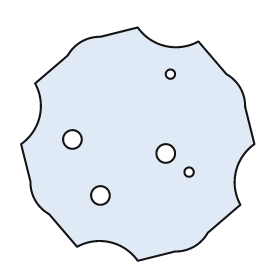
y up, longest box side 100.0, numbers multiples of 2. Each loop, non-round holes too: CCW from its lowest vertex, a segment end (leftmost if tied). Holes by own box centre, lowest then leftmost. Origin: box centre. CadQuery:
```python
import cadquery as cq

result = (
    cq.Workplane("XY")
    .moveTo(0.0, -50.0)
    .lineTo(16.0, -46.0)
    .threePointArc((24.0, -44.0), (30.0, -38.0))
    .lineTo(44.0, -26.0)
    .threePointArc((42.0, -12.0), (50.0, 0.0))
    .lineTo(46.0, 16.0)
    .threePointArc((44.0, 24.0), (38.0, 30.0))
    .lineTo(26.0, 44.0)
    .threePointArc((12.0, 42.0), (0.0, 50.0))
    .lineTo(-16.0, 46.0)
    .threePointArc((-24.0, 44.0), (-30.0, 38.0))
    .lineTo(-44.0, 26.0)
    .threePointArc((-42.0, 12.0), (-50.0, 0.0))
    .lineTo(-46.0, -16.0)
    .threePointArc((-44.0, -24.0), (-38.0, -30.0))
    .lineTo(-26.0, -44.0)
    .threePointArc((-12.0, -42.0), (0.0, -50.0))
    .close()
    .moveTo(-16.0, -22.0)
    .circle(4.0)
    .moveTo(22.0, -12.0)
    .circle(2.0)
    .moveTo(12.0, -4.0)
    .circle(4.0)
    .moveTo(-28.0, 2.0)
    .circle(4.0)
    .moveTo(14.0, 30.0)
    .circle(2.0)
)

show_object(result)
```